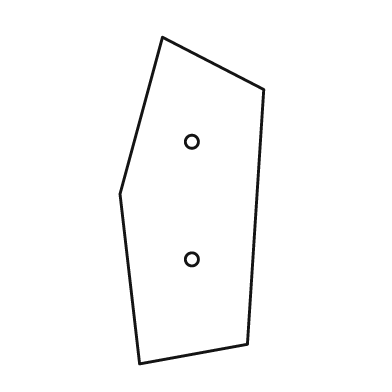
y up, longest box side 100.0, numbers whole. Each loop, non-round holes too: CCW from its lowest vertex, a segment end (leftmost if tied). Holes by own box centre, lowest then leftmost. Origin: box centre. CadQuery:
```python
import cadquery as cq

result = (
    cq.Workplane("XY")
    .moveTo(-16.0, -50.0)
    .lineTo(17.0, -44.0)
    .lineTo(22.0, 34.0)
    .lineTo(-9.0, 50.0)
    .lineTo(-22.0, 2.0)
    .close()
    .moveTo(0.0, -18.0)
    .circle(2.0)
    .moveTo(0.0, 18.0)
    .circle(2.0)
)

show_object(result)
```